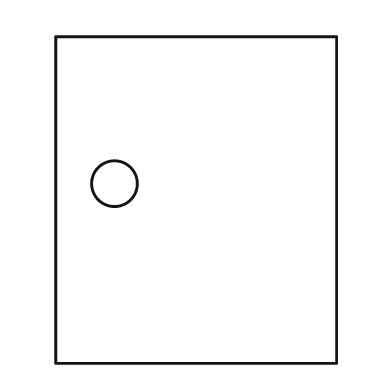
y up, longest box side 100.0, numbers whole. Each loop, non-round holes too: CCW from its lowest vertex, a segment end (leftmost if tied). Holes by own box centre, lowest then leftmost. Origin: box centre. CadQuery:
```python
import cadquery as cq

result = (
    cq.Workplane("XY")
    .moveTo(-43.0, -50.0)
    .lineTo(43.0, -50.0)
    .lineTo(43.0, 50.0)
    .lineTo(-43.0, 50.0)
    .close()
    .moveTo(-25.0, 5.0)
    .circle(7.0)
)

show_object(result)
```